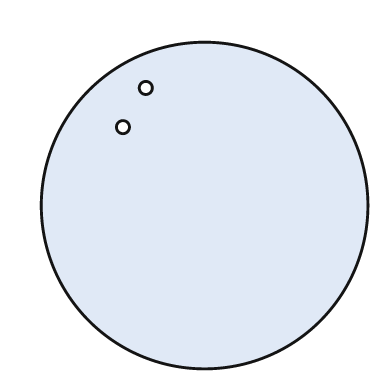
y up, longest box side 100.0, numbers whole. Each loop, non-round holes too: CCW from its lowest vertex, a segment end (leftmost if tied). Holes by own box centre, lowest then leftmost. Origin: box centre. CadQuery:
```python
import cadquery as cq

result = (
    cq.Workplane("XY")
    .moveTo(0.0, 0.0)
    .circle(50.0)
    .moveTo(-25.0, 24.0)
    .circle(2.0)
    .moveTo(-18.0, 36.0)
    .circle(2.0)
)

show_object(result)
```